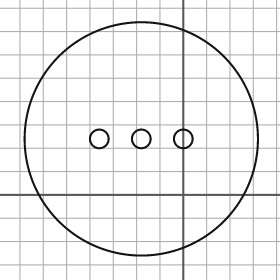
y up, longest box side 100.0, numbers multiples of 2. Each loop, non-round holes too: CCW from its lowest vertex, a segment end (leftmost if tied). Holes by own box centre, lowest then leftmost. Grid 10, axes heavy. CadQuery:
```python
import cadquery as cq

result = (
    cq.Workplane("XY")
    .moveTo(-18.0, 24.0)
    .circle(50.0)
    .moveTo(-36.0, 24.0)
    .circle(4.0)
    .moveTo(-18.0, 24.0)
    .circle(4.0)
    .moveTo(0.0, 24.0)
    .circle(4.0)
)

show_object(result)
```